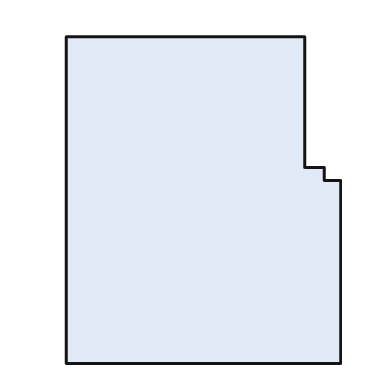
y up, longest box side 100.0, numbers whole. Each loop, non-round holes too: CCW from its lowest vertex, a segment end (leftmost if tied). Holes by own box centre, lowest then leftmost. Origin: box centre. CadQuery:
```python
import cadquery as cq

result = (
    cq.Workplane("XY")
    .moveTo(-42.0, -50.0)
    .lineTo(42.0, -50.0)
    .lineTo(42.0, 6.0)
    .lineTo(37.0, 6.0)
    .lineTo(37.0, 10.0)
    .lineTo(31.0, 10.0)
    .lineTo(31.0, 50.0)
    .lineTo(-42.0, 50.0)
    .close()
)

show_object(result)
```